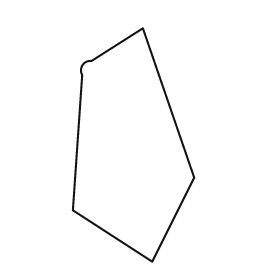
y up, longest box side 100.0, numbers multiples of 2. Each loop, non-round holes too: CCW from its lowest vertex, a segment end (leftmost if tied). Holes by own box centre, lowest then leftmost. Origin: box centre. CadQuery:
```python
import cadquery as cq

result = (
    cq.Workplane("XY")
    .moveTo(8.0, -50.0)
    .lineTo(26.0, -14.0)
    .lineTo(4.0, 50.0)
    .lineTo(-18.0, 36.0)
    .threePointArc((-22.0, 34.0), (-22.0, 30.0))
    .lineTo(-26.0, -28.0)
    .close()
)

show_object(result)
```